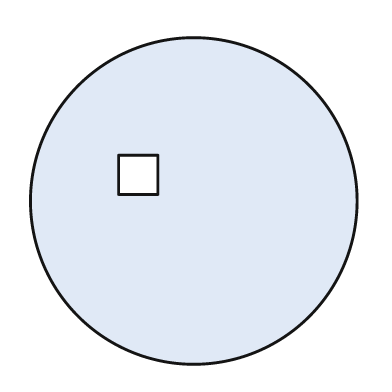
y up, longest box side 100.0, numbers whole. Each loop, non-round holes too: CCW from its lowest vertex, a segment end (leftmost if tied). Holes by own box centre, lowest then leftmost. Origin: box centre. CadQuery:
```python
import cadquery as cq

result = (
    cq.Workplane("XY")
    .moveTo(0.0, 0.0)
    .circle(50.0)
    .moveTo(-23.0, 2.0)
    .lineTo(-11.0, 2.0)
    .lineTo(-11.0, 14.0)
    .lineTo(-23.0, 14.0)
    .close()
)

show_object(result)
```